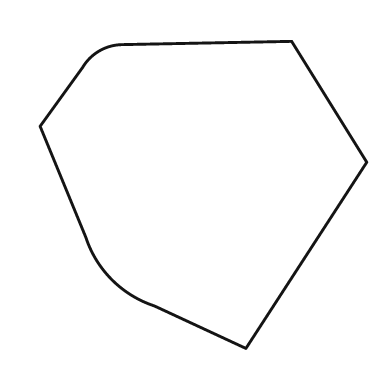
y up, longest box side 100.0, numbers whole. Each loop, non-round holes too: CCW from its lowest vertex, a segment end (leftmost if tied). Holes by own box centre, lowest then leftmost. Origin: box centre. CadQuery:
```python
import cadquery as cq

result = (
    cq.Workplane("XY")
    .moveTo(13.0, -47.0)
    .lineTo(50.0, 10.0)
    .lineTo(27.0, 47.0)
    .lineTo(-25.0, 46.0)
    .threePointArc((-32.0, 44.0), (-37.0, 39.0))
    .lineTo(-50.0, 21.0)
    .lineTo(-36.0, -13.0)
    .threePointArc((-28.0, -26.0), (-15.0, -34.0))
    .close()
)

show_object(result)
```